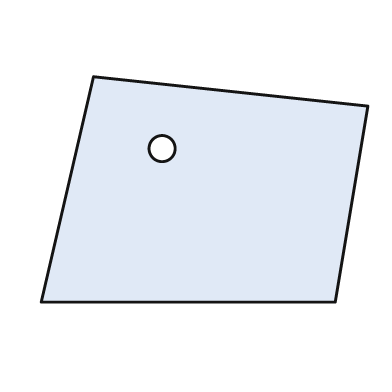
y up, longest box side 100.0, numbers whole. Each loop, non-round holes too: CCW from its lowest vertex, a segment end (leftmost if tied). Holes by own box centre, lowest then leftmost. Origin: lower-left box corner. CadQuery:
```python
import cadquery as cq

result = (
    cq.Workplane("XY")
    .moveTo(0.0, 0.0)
    .lineTo(90.0, 0.0)
    .lineTo(100.0, 60.0)
    .lineTo(16.0, 69.0)
    .close()
    .moveTo(37.0, 47.0)
    .circle(4.0)
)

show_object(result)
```